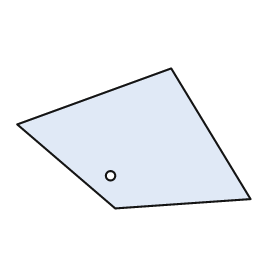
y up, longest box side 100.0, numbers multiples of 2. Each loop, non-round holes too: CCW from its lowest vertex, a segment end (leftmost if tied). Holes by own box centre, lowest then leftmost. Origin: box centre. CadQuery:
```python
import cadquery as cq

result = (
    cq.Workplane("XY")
    .moveTo(-8.0, -30.0)
    .lineTo(50.0, -26.0)
    .lineTo(16.0, 30.0)
    .lineTo(-50.0, 6.0)
    .close()
    .moveTo(-10.0, -16.0)
    .circle(2.0)
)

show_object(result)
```